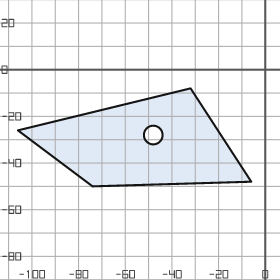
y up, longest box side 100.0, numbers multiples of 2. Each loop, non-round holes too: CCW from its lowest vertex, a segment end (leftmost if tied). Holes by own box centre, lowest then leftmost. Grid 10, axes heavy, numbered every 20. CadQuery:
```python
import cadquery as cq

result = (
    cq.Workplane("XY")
    .moveTo(-74.0, -50.0)
    .lineTo(-6.0, -48.0)
    .lineTo(-32.0, -8.0)
    .lineTo(-106.0, -26.0)
    .close()
    .moveTo(-48.0, -28.0)
    .circle(4.0)
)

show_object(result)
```